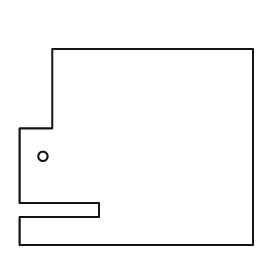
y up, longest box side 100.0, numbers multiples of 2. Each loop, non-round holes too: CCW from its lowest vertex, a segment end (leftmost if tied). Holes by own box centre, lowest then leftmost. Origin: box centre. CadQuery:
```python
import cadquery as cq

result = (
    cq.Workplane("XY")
    .moveTo(-50.0, -42.0)
    .lineTo(50.0, -42.0)
    .lineTo(50.0, 42.0)
    .lineTo(-36.0, 42.0)
    .lineTo(-36.0, 8.0)
    .lineTo(-50.0, 8.0)
    .lineTo(-50.0, -24.0)
    .lineTo(-16.0, -24.0)
    .lineTo(-16.0, -30.0)
    .lineTo(-50.0, -30.0)
    .close()
    .moveTo(-40.0, -4.0)
    .circle(2.0)
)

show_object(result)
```